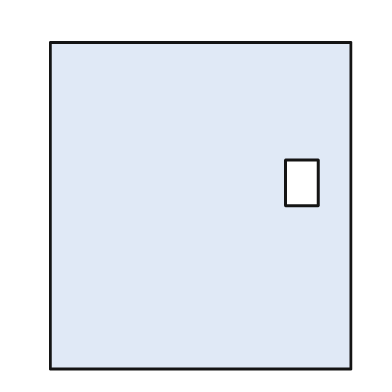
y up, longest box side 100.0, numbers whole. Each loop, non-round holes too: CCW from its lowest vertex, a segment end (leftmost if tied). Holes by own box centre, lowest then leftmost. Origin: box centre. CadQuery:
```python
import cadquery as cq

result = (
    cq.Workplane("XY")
    .moveTo(-46.0, -50.0)
    .lineTo(46.0, -50.0)
    .lineTo(46.0, 50.0)
    .lineTo(-46.0, 50.0)
    .close()
    .moveTo(26.0, 0.0)
    .lineTo(36.0, 0.0)
    .lineTo(36.0, 14.0)
    .lineTo(26.0, 14.0)
    .close()
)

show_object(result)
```